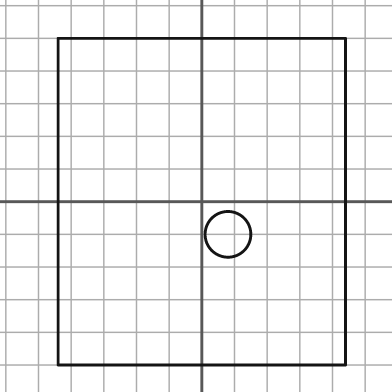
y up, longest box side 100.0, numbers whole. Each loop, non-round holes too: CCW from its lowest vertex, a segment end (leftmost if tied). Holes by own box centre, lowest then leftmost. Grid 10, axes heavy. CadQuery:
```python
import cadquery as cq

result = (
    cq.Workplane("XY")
    .moveTo(-44.0, -50.0)
    .lineTo(44.0, -50.0)
    .lineTo(44.0, 50.0)
    .lineTo(-44.0, 50.0)
    .close()
    .moveTo(8.0, -10.0)
    .circle(7.0)
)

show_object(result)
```